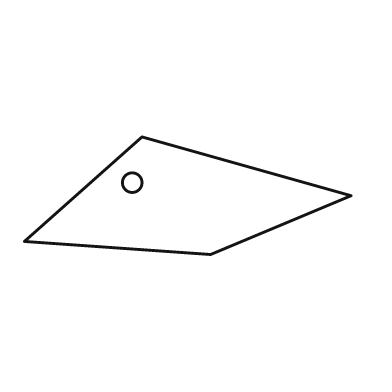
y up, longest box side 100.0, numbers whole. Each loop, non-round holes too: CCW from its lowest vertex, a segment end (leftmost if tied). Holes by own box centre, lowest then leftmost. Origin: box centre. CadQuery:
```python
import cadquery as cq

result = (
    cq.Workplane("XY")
    .moveTo(7.0, -18.0)
    .lineTo(50.0, 0.0)
    .lineTo(-14.0, 18.0)
    .lineTo(-50.0, -14.0)
    .close()
    .moveTo(-17.0, 4.0)
    .circle(3.0)
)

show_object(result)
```